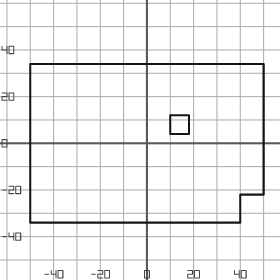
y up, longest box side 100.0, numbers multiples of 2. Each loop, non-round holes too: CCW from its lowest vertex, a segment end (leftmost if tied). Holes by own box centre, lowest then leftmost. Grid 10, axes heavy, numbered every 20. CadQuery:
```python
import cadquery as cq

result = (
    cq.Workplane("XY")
    .moveTo(-50.0, -34.0)
    .lineTo(40.0, -34.0)
    .lineTo(40.0, -22.0)
    .lineTo(50.0, -22.0)
    .lineTo(50.0, 34.0)
    .lineTo(-50.0, 34.0)
    .close()
    .moveTo(10.0, 4.0)
    .lineTo(18.0, 4.0)
    .lineTo(18.0, 12.0)
    .lineTo(10.0, 12.0)
    .close()
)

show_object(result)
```